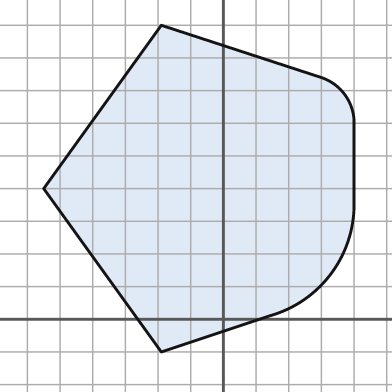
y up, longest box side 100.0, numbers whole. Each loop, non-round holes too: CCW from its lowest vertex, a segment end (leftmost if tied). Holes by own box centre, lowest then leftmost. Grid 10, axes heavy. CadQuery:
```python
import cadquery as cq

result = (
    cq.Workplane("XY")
    .moveTo(-19.0, -10.0)
    .lineTo(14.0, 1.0)
    .threePointArc((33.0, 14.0), (40.0, 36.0))
    .lineTo(40.0, 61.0)
    .threePointArc((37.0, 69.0), (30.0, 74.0))
    .lineTo(-19.0, 90.0)
    .lineTo(-55.0, 40.0)
    .close()
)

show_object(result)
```